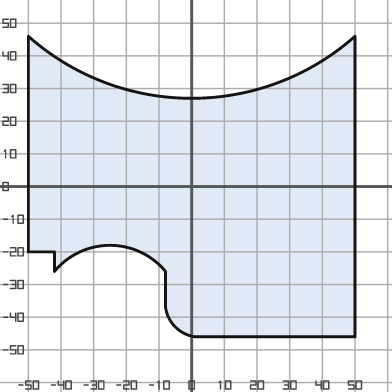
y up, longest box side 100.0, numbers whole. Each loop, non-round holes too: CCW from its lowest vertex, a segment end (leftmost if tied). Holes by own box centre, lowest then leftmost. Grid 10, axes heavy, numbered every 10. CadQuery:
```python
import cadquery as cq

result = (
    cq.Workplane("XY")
    .moveTo(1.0, -46.0)
    .lineTo(50.0, -46.0)
    .lineTo(50.0, 46.0)
    .threePointArc((0.0, 27.0), (-50.0, 46.0))
    .lineTo(-50.0, -20.0)
    .lineTo(-42.0, -20.0)
    .lineTo(-42.0, -26.0)
    .threePointArc((-25.0, -18.0), (-8.0, -26.0))
    .lineTo(-8.0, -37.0)
    .threePointArc((-5.0, -43.0), (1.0, -46.0))
    .close()
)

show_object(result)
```